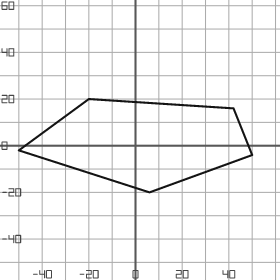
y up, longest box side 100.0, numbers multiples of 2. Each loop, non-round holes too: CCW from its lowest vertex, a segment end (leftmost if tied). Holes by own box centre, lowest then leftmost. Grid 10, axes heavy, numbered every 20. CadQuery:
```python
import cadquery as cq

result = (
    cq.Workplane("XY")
    .moveTo(6.0, -20.0)
    .lineTo(50.0, -4.0)
    .lineTo(42.0, 16.0)
    .lineTo(-20.0, 20.0)
    .lineTo(-50.0, -2.0)
    .close()
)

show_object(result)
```